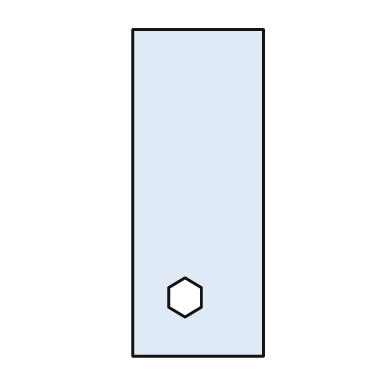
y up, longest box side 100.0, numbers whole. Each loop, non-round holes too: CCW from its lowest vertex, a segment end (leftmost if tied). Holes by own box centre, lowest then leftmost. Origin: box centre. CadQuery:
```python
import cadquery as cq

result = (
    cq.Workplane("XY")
    .moveTo(-20.0, -50.0)
    .lineTo(20.0, -50.0)
    .lineTo(20.0, 50.0)
    .lineTo(-20.0, 50.0)
    .close()
    .moveTo(-4.0, -38.0)
    .lineTo(1.0, -35.0)
    .lineTo(1.0, -29.0)
    .lineTo(-4.0, -26.0)
    .lineTo(-9.0, -29.0)
    .lineTo(-9.0, -35.0)
    .close()
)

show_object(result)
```